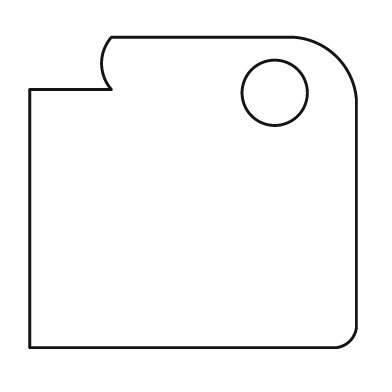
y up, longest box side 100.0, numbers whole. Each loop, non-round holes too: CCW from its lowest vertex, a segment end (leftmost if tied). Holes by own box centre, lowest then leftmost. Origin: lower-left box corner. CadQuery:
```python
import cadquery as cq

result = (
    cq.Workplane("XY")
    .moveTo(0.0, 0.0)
    .lineTo(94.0, 0.0)
    .threePointArc((98.0, 2.0), (100.0, 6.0))
    .lineTo(100.0, 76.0)
    .threePointArc((94.0, 89.0), (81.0, 95.0))
    .lineTo(25.0, 95.0)
    .threePointArc((22.0, 87.0), (25.0, 79.0))
    .lineTo(0.0, 79.0)
    .close()
    .moveTo(75.0, 78.0)
    .circle(10.0)
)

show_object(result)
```